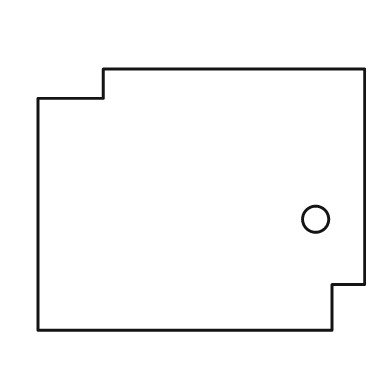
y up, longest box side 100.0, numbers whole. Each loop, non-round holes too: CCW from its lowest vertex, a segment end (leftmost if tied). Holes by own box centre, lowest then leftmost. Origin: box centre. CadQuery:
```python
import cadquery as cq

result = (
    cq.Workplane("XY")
    .moveTo(-50.0, -40.0)
    .lineTo(40.0, -40.0)
    .lineTo(40.0, -26.0)
    .lineTo(50.0, -26.0)
    .lineTo(50.0, 40.0)
    .lineTo(-30.0, 40.0)
    .lineTo(-30.0, 31.0)
    .lineTo(-50.0, 31.0)
    .close()
    .moveTo(35.0, -6.0)
    .circle(4.0)
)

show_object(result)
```